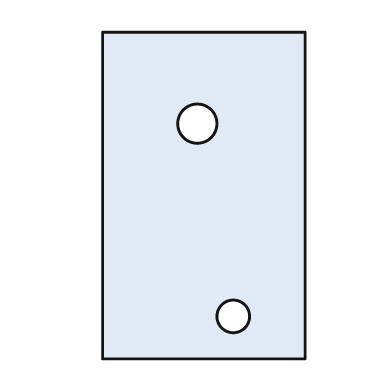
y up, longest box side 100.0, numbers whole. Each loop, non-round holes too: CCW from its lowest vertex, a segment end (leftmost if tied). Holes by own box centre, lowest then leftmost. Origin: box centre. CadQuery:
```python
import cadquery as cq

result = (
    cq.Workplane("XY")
    .moveTo(-31.0, -50.0)
    .lineTo(31.0, -50.0)
    .lineTo(31.0, 50.0)
    .lineTo(-31.0, 50.0)
    .close()
    .moveTo(9.0, -37.0)
    .circle(5.0)
    .moveTo(-2.0, 22.0)
    .circle(6.0)
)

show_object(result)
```